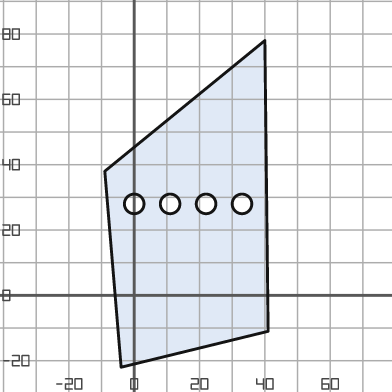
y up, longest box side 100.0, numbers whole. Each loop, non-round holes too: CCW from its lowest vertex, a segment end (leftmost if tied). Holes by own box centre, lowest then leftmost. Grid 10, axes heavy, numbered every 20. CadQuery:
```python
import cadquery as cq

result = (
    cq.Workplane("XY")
    .moveTo(-4.0, -22.0)
    .lineTo(41.0, -11.0)
    .lineTo(40.0, 78.0)
    .lineTo(-9.0, 38.0)
    .close()
    .moveTo(0.0, 28.0)
    .circle(3.0)
    .moveTo(11.0, 28.0)
    .circle(3.0)
    .moveTo(22.0, 28.0)
    .circle(3.0)
    .moveTo(33.0, 28.0)
    .circle(3.0)
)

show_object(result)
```